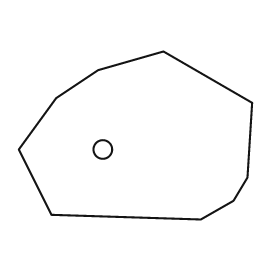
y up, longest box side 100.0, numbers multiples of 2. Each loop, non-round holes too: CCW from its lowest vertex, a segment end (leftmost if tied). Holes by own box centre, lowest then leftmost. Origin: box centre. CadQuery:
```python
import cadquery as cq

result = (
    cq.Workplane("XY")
    .moveTo(28.0, -36.0)
    .lineTo(42.0, -28.0)
    .lineTo(48.0, -18.0)
    .lineTo(50.0, 14.0)
    .lineTo(12.0, 36.0)
    .lineTo(-16.0, 28.0)
    .lineTo(-34.0, 16.0)
    .lineTo(-50.0, -6.0)
    .lineTo(-36.0, -34.0)
    .close()
    .moveTo(-14.0, -6.0)
    .circle(4.0)
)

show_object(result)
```